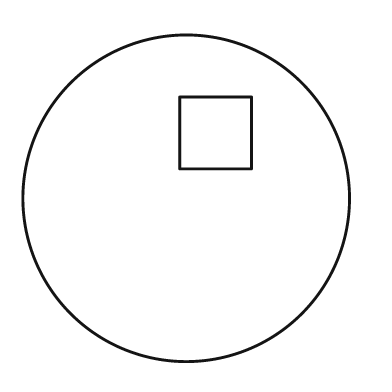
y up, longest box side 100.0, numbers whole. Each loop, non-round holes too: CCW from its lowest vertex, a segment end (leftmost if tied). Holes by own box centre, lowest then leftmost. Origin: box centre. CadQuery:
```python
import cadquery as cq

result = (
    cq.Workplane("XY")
    .moveTo(0.0, 0.0)
    .circle(50.0)
    .moveTo(-2.0, 9.0)
    .lineTo(20.0, 9.0)
    .lineTo(20.0, 31.0)
    .lineTo(-2.0, 31.0)
    .close()
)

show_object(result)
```